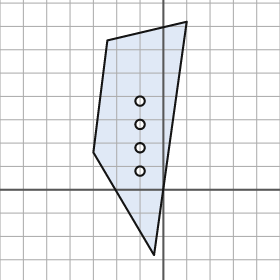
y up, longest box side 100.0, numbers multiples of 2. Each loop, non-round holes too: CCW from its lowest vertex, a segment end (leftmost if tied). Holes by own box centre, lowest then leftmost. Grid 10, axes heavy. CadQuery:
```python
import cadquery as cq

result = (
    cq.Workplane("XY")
    .moveTo(-4.0, -28.0)
    .lineTo(10.0, 72.0)
    .lineTo(-24.0, 64.0)
    .lineTo(-30.0, 16.0)
    .close()
    .moveTo(-10.0, 8.0)
    .circle(2.0)
    .moveTo(-10.0, 18.0)
    .circle(2.0)
    .moveTo(-10.0, 28.0)
    .circle(2.0)
    .moveTo(-10.0, 38.0)
    .circle(2.0)
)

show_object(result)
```